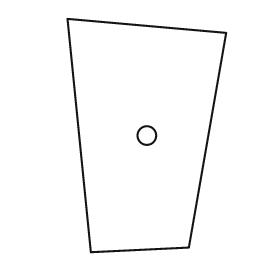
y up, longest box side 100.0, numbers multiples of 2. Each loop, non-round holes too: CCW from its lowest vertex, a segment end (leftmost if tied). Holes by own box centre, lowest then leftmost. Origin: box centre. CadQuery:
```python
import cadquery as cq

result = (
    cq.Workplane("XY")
    .moveTo(-24.0, -50.0)
    .lineTo(18.0, -48.0)
    .lineTo(34.0, 44.0)
    .lineTo(-34.0, 50.0)
    .close()
    .moveTo(0.0, 0.0)
    .circle(4.0)
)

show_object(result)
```